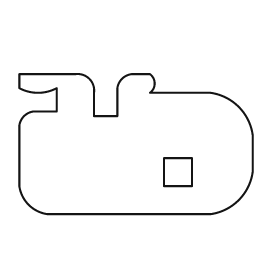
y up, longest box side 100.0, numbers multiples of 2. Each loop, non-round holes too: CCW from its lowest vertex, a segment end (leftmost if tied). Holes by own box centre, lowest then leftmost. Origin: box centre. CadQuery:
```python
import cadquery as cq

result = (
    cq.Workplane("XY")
    .moveTo(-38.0, -30.0)
    .lineTo(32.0, -30.0)
    .threePointArc((44.0, -24.0), (50.0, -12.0))
    .lineTo(50.0, 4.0)
    .threePointArc((44.0, 16.0), (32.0, 22.0))
    .lineTo(6.0, 22.0)
    .threePointArc((8.0, 26.0), (6.0, 30.0))
    .lineTo(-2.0, 30.0)
    .threePointArc((-6.0, 28.0), (-8.0, 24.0))
    .lineTo(-8.0, 12.0)
    .lineTo(-18.0, 12.0)
    .lineTo(-18.0, 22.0)
    .threePointArc((-20.0, 28.0), (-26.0, 30.0))
    .lineTo(-50.0, 30.0)
    .lineTo(-50.0, 24.0)
    .threePointArc((-42.0, 22.0), (-34.0, 24.0))
    .lineTo(-34.0, 14.0)
    .lineTo(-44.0, 14.0)
    .threePointArc((-48.0, 12.0), (-50.0, 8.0))
    .lineTo(-50.0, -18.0)
    .threePointArc((-46.0, -26.0), (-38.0, -30.0))
    .close()
    .moveTo(12.0, -18.0)
    .lineTo(24.0, -18.0)
    .lineTo(24.0, -6.0)
    .lineTo(12.0, -6.0)
    .close()
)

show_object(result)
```